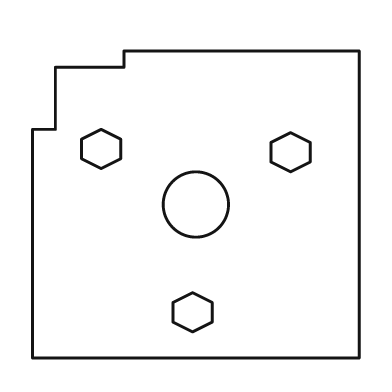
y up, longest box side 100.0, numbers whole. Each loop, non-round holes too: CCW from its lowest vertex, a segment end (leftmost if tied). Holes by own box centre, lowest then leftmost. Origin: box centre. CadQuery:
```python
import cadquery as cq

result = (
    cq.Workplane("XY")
    .moveTo(-50.0, -47.0)
    .lineTo(50.0, -47.0)
    .lineTo(50.0, 47.0)
    .lineTo(-22.0, 47.0)
    .lineTo(-22.0, 42.0)
    .lineTo(-43.0, 42.0)
    .lineTo(-43.0, 23.0)
    .lineTo(-50.0, 23.0)
    .close()
    .moveTo(-1.0, -39.0)
    .lineTo(5.0, -36.0)
    .lineTo(5.0, -30.0)
    .lineTo(-1.0, -27.0)
    .lineTo(-7.0, -30.0)
    .lineTo(-7.0, -36.0)
    .close()
    .moveTo(0.0, 0.0)
    .circle(10.0)
    .moveTo(29.0, 10.0)
    .lineTo(35.0, 13.0)
    .lineTo(35.0, 19.0)
    .lineTo(29.0, 22.0)
    .lineTo(23.0, 19.0)
    .lineTo(23.0, 13.0)
    .close()
    .moveTo(-29.0, 11.0)
    .lineTo(-23.0, 14.0)
    .lineTo(-23.0, 20.0)
    .lineTo(-29.0, 23.0)
    .lineTo(-35.0, 20.0)
    .lineTo(-35.0, 14.0)
    .close()
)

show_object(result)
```